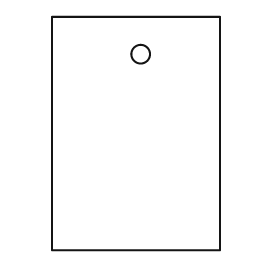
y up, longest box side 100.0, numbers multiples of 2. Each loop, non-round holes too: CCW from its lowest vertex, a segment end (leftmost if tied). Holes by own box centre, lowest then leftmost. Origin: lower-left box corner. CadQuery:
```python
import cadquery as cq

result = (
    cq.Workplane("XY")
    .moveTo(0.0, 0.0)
    .lineTo(72.0, 0.0)
    .lineTo(72.0, 100.0)
    .lineTo(0.0, 100.0)
    .close()
    .moveTo(38.0, 84.0)
    .circle(4.0)
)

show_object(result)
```